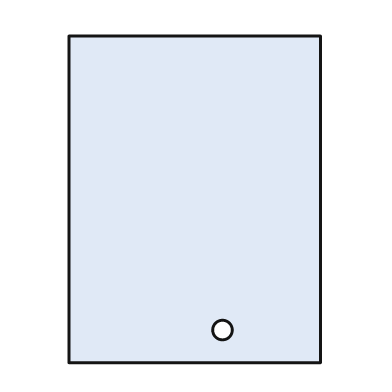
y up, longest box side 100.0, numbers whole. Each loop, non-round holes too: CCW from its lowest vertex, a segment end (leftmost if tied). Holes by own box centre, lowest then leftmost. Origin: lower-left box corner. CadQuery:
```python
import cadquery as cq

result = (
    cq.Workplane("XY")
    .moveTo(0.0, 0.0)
    .lineTo(77.0, 0.0)
    .lineTo(77.0, 100.0)
    .lineTo(0.0, 100.0)
    .close()
    .moveTo(47.0, 10.0)
    .circle(3.0)
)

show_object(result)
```